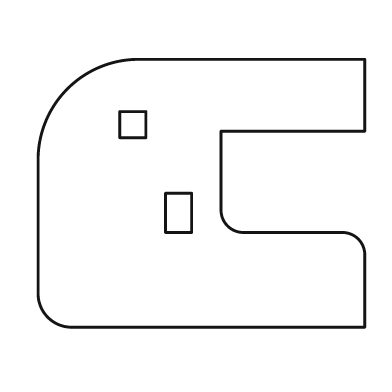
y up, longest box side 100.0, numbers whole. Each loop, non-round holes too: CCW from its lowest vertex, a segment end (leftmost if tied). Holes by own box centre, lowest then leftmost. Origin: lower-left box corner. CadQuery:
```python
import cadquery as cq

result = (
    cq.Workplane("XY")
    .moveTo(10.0, 0.0)
    .lineTo(100.0, 0.0)
    .lineTo(100.0, 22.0)
    .threePointArc((98.0, 27.0), (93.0, 29.0))
    .lineTo(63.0, 29.0)
    .threePointArc((58.0, 31.0), (56.0, 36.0))
    .lineTo(56.0, 60.0)
    .lineTo(100.0, 60.0)
    .lineTo(100.0, 82.0)
    .lineTo(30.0, 82.0)
    .threePointArc((9.0, 73.0), (0.0, 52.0))
    .lineTo(0.0, 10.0)
    .threePointArc((3.0, 3.0), (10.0, 0.0))
    .close()
    .moveTo(39.0, 29.0)
    .lineTo(47.0, 29.0)
    .lineTo(47.0, 41.0)
    .lineTo(39.0, 41.0)
    .close()
    .moveTo(25.0, 58.0)
    .lineTo(33.0, 58.0)
    .lineTo(33.0, 66.0)
    .lineTo(25.0, 66.0)
    .close()
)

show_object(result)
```